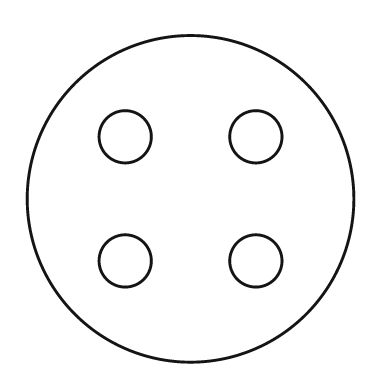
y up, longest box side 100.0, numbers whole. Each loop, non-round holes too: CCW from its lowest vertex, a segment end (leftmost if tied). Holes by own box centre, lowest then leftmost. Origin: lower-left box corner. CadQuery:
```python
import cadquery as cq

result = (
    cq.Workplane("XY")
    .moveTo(50.0, 50.0)
    .circle(50.0)
    .moveTo(30.0, 31.0)
    .circle(8.0)
    .moveTo(70.0, 31.0)
    .circle(8.0)
    .moveTo(30.0, 69.0)
    .circle(8.0)
    .moveTo(70.0, 69.0)
    .circle(8.0)
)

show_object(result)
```